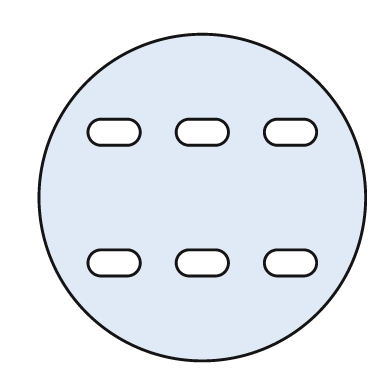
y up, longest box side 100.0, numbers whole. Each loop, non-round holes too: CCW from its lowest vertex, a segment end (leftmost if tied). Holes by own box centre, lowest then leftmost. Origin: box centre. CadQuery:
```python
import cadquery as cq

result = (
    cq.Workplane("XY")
    .moveTo(0.0, 0.0)
    .circle(50.0)
    .moveTo(-31.0, -24.0)
    .lineTo(-23.0, -24.0)
    .threePointArc((-19.0, -20.0), (-23.0, -16.0))
    .lineTo(-31.0, -16.0)
    .threePointArc((-35.0, -20.0), (-31.0, -24.0))
    .close()
    .moveTo(-4.0, -24.0)
    .lineTo(4.0, -24.0)
    .threePointArc((8.0, -20.0), (4.0, -16.0))
    .lineTo(-4.0, -16.0)
    .threePointArc((-8.0, -20.0), (-4.0, -24.0))
    .close()
    .moveTo(23.0, -24.0)
    .lineTo(31.0, -24.0)
    .threePointArc((35.0, -20.0), (31.0, -16.0))
    .lineTo(23.0, -16.0)
    .threePointArc((19.0, -20.0), (23.0, -24.0))
    .close()
    .moveTo(-31.0, 16.0)
    .lineTo(-23.0, 16.0)
    .threePointArc((-19.0, 20.0), (-23.0, 24.0))
    .lineTo(-31.0, 24.0)
    .threePointArc((-35.0, 20.0), (-31.0, 16.0))
    .close()
    .moveTo(-4.0, 16.0)
    .lineTo(4.0, 16.0)
    .threePointArc((8.0, 20.0), (4.0, 24.0))
    .lineTo(-4.0, 24.0)
    .threePointArc((-8.0, 20.0), (-4.0, 16.0))
    .close()
    .moveTo(23.0, 16.0)
    .lineTo(31.0, 16.0)
    .threePointArc((35.0, 20.0), (31.0, 24.0))
    .lineTo(23.0, 24.0)
    .threePointArc((19.0, 20.0), (23.0, 16.0))
    .close()
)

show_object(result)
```